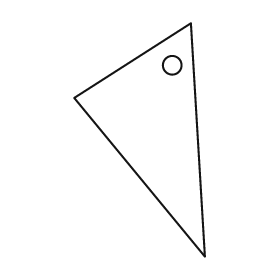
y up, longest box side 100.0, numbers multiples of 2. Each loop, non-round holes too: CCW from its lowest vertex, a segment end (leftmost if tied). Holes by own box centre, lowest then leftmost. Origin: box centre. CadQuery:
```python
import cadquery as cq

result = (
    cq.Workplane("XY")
    .moveTo(28.0, -50.0)
    .lineTo(22.0, 50.0)
    .lineTo(-28.0, 18.0)
    .close()
    .moveTo(14.0, 32.0)
    .circle(4.0)
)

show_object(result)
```